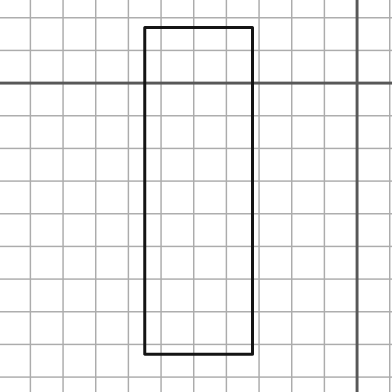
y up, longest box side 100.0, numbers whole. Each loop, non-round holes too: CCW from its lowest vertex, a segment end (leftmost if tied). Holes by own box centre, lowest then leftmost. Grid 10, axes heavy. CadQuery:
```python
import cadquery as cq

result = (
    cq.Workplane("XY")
    .moveTo(-65.0, -83.0)
    .lineTo(-32.0, -83.0)
    .lineTo(-32.0, 17.0)
    .lineTo(-65.0, 17.0)
    .close()
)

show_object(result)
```